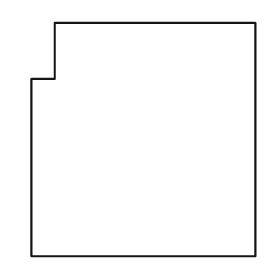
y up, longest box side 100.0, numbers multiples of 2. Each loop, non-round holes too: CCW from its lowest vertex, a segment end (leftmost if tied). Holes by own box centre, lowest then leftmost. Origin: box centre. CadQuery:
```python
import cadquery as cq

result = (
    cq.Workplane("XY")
    .moveTo(-48.0, -50.0)
    .lineTo(48.0, -50.0)
    .lineTo(48.0, 50.0)
    .lineTo(-38.0, 50.0)
    .lineTo(-38.0, 26.0)
    .lineTo(-48.0, 26.0)
    .close()
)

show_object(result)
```